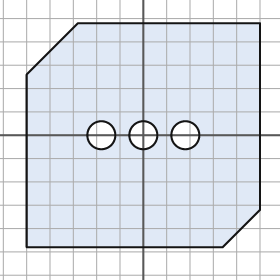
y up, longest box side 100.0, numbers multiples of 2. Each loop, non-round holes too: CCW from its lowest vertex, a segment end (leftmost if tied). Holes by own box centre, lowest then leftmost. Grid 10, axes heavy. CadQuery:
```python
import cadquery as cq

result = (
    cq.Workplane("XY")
    .moveTo(-50.0, -48.0)
    .lineTo(34.0, -48.0)
    .lineTo(50.0, -32.0)
    .lineTo(50.0, 48.0)
    .lineTo(-28.0, 48.0)
    .lineTo(-50.0, 26.0)
    .close()
    .moveTo(-18.0, 0.0)
    .circle(6.0)
    .moveTo(0.0, 0.0)
    .circle(6.0)
    .moveTo(18.0, 0.0)
    .circle(6.0)
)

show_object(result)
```